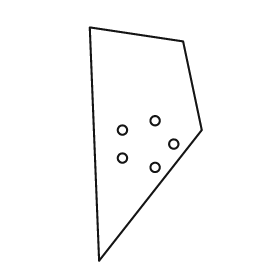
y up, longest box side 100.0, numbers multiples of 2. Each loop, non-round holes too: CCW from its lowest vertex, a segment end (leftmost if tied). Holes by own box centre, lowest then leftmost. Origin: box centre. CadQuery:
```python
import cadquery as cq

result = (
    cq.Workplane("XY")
    .moveTo(-20.0, -50.0)
    .lineTo(24.0, 6.0)
    .lineTo(16.0, 44.0)
    .lineTo(-24.0, 50.0)
    .close()
    .moveTo(4.0, -10.0)
    .circle(2.0)
    .moveTo(-10.0, -6.0)
    .circle(2.0)
    .moveTo(12.0, 0.0)
    .circle(2.0)
    .moveTo(-10.0, 6.0)
    .circle(2.0)
    .moveTo(4.0, 10.0)
    .circle(2.0)
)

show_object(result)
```